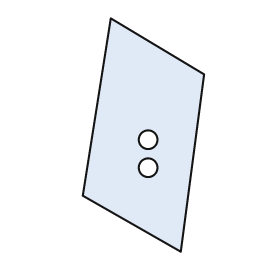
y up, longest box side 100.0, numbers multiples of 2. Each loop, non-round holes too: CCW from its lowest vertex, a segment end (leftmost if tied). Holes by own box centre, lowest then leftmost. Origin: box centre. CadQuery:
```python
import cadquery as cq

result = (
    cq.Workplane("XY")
    .moveTo(16.0, -50.0)
    .lineTo(26.0, 26.0)
    .lineTo(-14.0, 50.0)
    .lineTo(-26.0, -26.0)
    .close()
    .moveTo(2.0, -14.0)
    .circle(4.0)
    .moveTo(2.0, -2.0)
    .circle(4.0)
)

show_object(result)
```